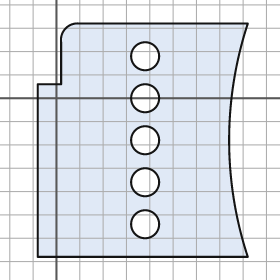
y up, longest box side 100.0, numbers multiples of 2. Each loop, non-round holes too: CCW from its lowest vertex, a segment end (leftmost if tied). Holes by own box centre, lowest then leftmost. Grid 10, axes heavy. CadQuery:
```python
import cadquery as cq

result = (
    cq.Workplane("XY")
    .moveTo(-8.0, -68.0)
    .lineTo(82.0, -68.0)
    .threePointArc((74.0, -18.0), (82.0, 32.0))
    .lineTo(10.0, 32.0)
    .threePointArc((4.0, 30.0), (2.0, 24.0))
    .lineTo(2.0, 6.0)
    .lineTo(-8.0, 6.0)
    .close()
    .moveTo(38.0, -54.0)
    .circle(6.0)
    .moveTo(38.0, -36.0)
    .circle(6.0)
    .moveTo(38.0, -18.0)
    .circle(6.0)
    .moveTo(38.0, 0.0)
    .circle(6.0)
    .moveTo(38.0, 18.0)
    .circle(6.0)
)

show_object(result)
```